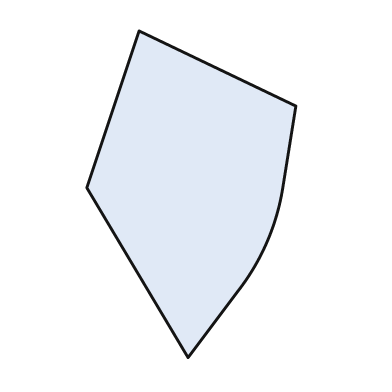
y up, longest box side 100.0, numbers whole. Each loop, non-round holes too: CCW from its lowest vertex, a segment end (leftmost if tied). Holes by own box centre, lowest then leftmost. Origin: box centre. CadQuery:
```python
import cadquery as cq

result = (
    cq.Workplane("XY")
    .moveTo(-1.0, -50.0)
    .lineTo(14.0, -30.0)
    .threePointArc((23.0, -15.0), (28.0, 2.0))
    .lineTo(32.0, 27.0)
    .lineTo(-16.0, 50.0)
    .lineTo(-32.0, 2.0)
    .close()
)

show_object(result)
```